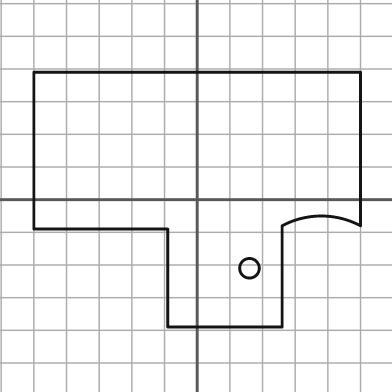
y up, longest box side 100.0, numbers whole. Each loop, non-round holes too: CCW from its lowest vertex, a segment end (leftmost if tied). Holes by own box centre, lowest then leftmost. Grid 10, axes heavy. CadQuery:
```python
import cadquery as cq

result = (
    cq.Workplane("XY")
    .moveTo(-9.0, -39.0)
    .lineTo(26.0, -39.0)
    .lineTo(26.0, -8.0)
    .threePointArc((38.0, -5.0), (50.0, -8.0))
    .lineTo(50.0, 39.0)
    .lineTo(-50.0, 39.0)
    .lineTo(-50.0, -9.0)
    .lineTo(-9.0, -9.0)
    .close()
    .moveTo(16.0, -21.0)
    .circle(3.0)
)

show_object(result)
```